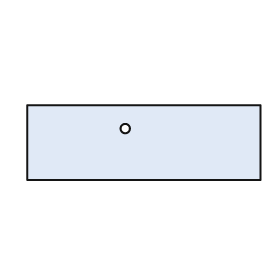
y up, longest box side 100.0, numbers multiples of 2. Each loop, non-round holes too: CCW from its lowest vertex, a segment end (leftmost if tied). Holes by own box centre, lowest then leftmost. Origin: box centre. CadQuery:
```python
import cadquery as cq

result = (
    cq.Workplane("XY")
    .moveTo(-50.0, -16.0)
    .lineTo(50.0, -16.0)
    .lineTo(50.0, 16.0)
    .lineTo(-50.0, 16.0)
    .close()
    .moveTo(-8.0, 6.0)
    .circle(2.0)
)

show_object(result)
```